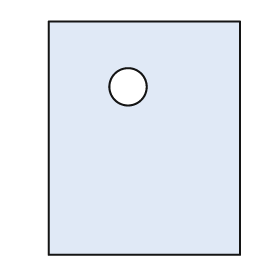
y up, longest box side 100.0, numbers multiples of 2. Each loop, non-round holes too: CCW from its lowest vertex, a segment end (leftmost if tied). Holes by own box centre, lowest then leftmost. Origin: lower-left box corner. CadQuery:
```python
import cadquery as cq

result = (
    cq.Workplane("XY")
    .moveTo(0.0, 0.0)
    .lineTo(82.0, 0.0)
    .lineTo(82.0, 100.0)
    .lineTo(0.0, 100.0)
    .close()
    .moveTo(34.0, 72.0)
    .circle(8.0)
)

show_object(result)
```